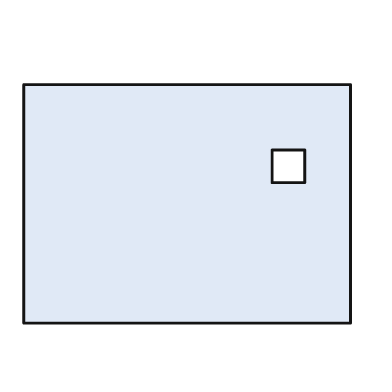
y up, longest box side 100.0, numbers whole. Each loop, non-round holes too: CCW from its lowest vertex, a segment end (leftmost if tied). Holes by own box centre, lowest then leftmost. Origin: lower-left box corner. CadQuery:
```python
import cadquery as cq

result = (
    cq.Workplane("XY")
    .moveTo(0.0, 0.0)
    .lineTo(100.0, 0.0)
    .lineTo(100.0, 73.0)
    .lineTo(0.0, 73.0)
    .close()
    .moveTo(76.0, 43.0)
    .lineTo(86.0, 43.0)
    .lineTo(86.0, 53.0)
    .lineTo(76.0, 53.0)
    .close()
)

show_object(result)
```